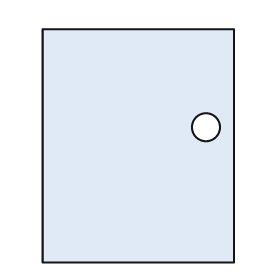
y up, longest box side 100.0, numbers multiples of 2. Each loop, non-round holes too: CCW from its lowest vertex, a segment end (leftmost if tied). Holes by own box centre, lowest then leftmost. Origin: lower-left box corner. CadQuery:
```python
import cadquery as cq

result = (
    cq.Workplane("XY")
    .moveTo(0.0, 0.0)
    .lineTo(82.0, 0.0)
    .lineTo(82.0, 100.0)
    .lineTo(0.0, 100.0)
    .close()
    .moveTo(70.0, 58.0)
    .circle(6.0)
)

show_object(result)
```